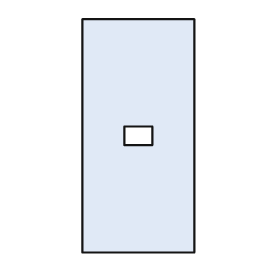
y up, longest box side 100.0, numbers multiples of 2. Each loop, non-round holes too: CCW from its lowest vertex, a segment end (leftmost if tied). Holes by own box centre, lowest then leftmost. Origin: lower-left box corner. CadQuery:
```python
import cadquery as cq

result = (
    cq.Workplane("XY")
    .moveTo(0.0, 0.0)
    .lineTo(48.0, 0.0)
    .lineTo(48.0, 100.0)
    .lineTo(0.0, 100.0)
    .close()
    .moveTo(18.0, 46.0)
    .lineTo(30.0, 46.0)
    .lineTo(30.0, 54.0)
    .lineTo(18.0, 54.0)
    .close()
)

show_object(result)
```